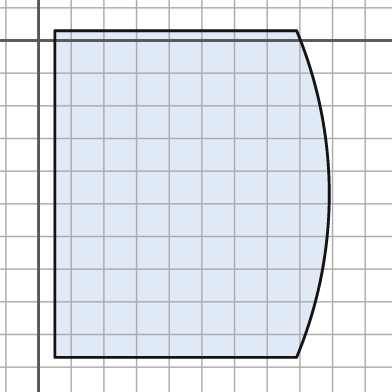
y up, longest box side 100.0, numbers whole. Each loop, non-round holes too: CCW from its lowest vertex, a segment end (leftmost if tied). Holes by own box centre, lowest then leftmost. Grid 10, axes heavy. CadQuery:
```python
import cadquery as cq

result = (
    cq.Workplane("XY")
    .moveTo(5.0, -97.0)
    .lineTo(79.0, -97.0)
    .threePointArc((89.0, -47.0), (79.0, 3.0))
    .lineTo(5.0, 3.0)
    .close()
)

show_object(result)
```